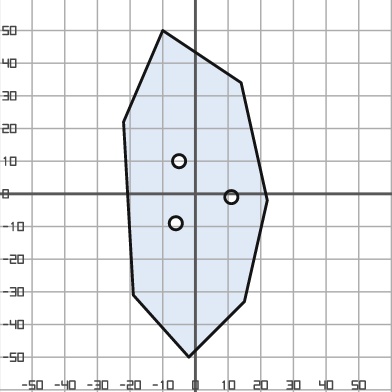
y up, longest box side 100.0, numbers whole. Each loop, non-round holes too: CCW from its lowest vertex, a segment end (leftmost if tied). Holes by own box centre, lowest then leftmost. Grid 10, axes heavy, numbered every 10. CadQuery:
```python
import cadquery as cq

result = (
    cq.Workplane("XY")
    .moveTo(-2.0, -50.0)
    .lineTo(15.0, -33.0)
    .lineTo(22.0, -2.0)
    .lineTo(14.0, 34.0)
    .lineTo(-10.0, 50.0)
    .lineTo(-22.0, 22.0)
    .lineTo(-19.0, -31.0)
    .close()
    .moveTo(-6.0, -9.0)
    .circle(2.0)
    .moveTo(11.0, -1.0)
    .circle(2.0)
    .moveTo(-5.0, 10.0)
    .circle(2.0)
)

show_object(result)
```